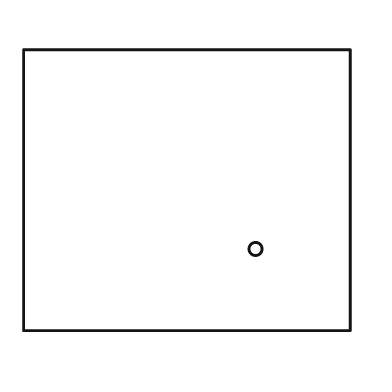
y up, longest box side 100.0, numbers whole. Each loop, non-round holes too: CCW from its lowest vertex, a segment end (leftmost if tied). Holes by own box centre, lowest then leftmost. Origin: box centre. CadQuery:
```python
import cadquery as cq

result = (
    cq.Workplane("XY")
    .moveTo(-50.0, -43.0)
    .lineTo(50.0, -43.0)
    .lineTo(50.0, 43.0)
    .lineTo(-50.0, 43.0)
    .close()
    .moveTo(21.0, -18.0)
    .circle(2.0)
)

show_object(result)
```